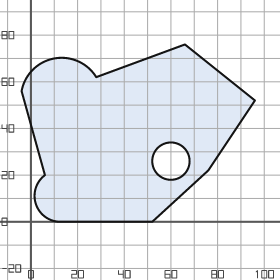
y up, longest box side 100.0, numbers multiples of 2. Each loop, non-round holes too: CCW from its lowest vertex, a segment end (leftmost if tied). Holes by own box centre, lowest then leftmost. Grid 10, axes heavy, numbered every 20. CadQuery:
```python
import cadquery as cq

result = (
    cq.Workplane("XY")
    .moveTo(12.0, 0.0)
    .lineTo(52.0, 0.0)
    .lineTo(76.0, 22.0)
    .lineTo(96.0, 52.0)
    .lineTo(66.0, 76.0)
    .lineTo(28.0, 62.0)
    .threePointArc((10.0, 70.0), (-4.0, 56.0))
    .lineTo(6.0, 20.0)
    .threePointArc((2.0, 8.0), (12.0, 0.0))
    .close()
    .moveTo(60.0, 26.0)
    .circle(8.0)
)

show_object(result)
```